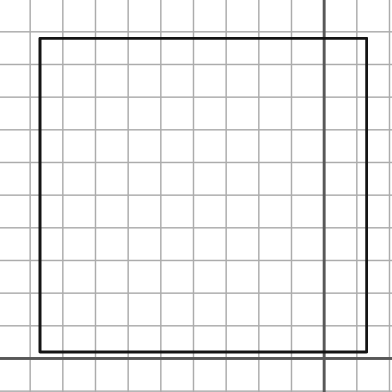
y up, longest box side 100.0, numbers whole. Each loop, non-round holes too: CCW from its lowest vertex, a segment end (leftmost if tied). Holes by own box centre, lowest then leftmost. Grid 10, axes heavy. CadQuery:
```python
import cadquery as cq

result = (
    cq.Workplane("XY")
    .moveTo(-87.0, 2.0)
    .lineTo(13.0, 2.0)
    .lineTo(13.0, 98.0)
    .lineTo(-87.0, 98.0)
    .close()
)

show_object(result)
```